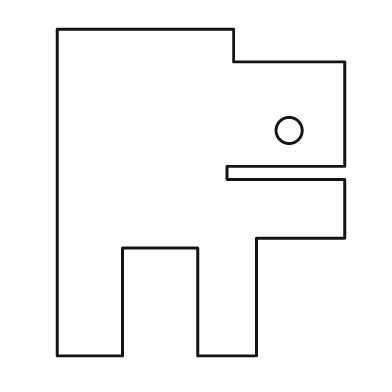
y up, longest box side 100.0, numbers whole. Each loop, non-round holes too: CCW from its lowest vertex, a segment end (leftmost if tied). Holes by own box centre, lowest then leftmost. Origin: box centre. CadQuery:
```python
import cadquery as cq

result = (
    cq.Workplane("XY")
    .moveTo(-44.0, -50.0)
    .lineTo(-24.0, -50.0)
    .lineTo(-24.0, -17.0)
    .lineTo(-1.0, -17.0)
    .lineTo(-1.0, -50.0)
    .lineTo(17.0, -50.0)
    .lineTo(17.0, -14.0)
    .lineTo(44.0, -14.0)
    .lineTo(44.0, 4.0)
    .lineTo(8.0, 4.0)
    .lineTo(8.0, 8.0)
    .lineTo(44.0, 8.0)
    .lineTo(44.0, 40.0)
    .lineTo(10.0, 40.0)
    .lineTo(10.0, 50.0)
    .lineTo(-44.0, 50.0)
    .close()
    .moveTo(27.0, 19.0)
    .circle(4.0)
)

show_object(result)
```